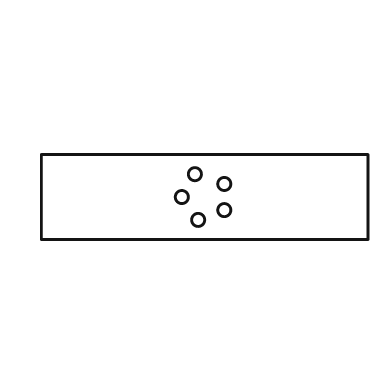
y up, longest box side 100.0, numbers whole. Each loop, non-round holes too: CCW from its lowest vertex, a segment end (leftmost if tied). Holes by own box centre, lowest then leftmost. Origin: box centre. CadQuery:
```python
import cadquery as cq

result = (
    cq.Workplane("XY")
    .moveTo(-50.0, -13.0)
    .lineTo(50.0, -13.0)
    .lineTo(50.0, 13.0)
    .lineTo(-50.0, 13.0)
    .close()
    .moveTo(-2.0, -7.0)
    .circle(2.0)
    .moveTo(6.0, -4.0)
    .circle(2.0)
    .moveTo(-7.0, 0.0)
    .circle(2.0)
    .moveTo(6.0, 4.0)
    .circle(2.0)
    .moveTo(-3.0, 7.0)
    .circle(2.0)
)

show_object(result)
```